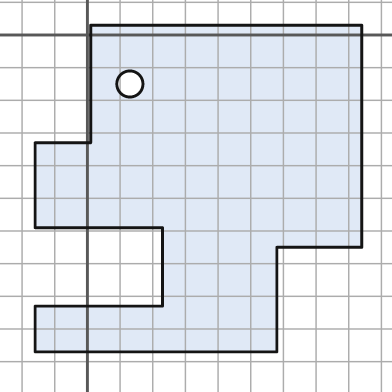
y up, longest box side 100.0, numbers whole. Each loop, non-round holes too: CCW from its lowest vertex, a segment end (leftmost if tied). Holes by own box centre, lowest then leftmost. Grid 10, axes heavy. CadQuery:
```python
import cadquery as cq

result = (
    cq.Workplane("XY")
    .moveTo(-16.0, -97.0)
    .lineTo(58.0, -97.0)
    .lineTo(58.0, -65.0)
    .lineTo(84.0, -65.0)
    .lineTo(84.0, 3.0)
    .lineTo(1.0, 3.0)
    .lineTo(1.0, -33.0)
    .lineTo(-16.0, -33.0)
    .lineTo(-16.0, -59.0)
    .lineTo(23.0, -59.0)
    .lineTo(23.0, -83.0)
    .lineTo(-16.0, -83.0)
    .close()
    .moveTo(13.0, -15.0)
    .circle(4.0)
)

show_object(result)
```